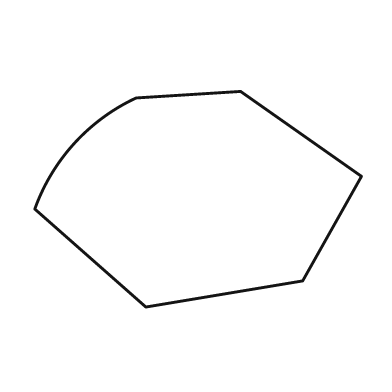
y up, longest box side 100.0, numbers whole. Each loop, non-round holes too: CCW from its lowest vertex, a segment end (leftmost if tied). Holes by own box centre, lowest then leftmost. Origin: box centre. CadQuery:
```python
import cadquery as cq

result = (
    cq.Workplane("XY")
    .moveTo(-16.0, -33.0)
    .lineTo(32.0, -25.0)
    .lineTo(50.0, 7.0)
    .lineTo(13.0, 33.0)
    .lineTo(-19.0, 31.0)
    .threePointArc((-38.0, 17.0), (-50.0, -3.0))
    .close()
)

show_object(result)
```